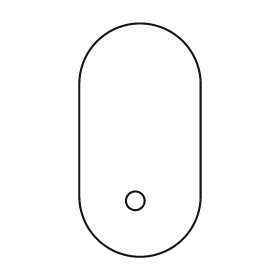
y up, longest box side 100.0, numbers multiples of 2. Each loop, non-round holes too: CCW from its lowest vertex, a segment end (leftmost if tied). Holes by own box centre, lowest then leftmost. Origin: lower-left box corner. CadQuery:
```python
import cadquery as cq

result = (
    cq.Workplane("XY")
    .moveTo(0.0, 26.0)
    .threePointArc((26.0, 0.0), (52.0, 26.0))
    .lineTo(52.0, 74.0)
    .threePointArc((26.0, 100.0), (0.0, 74.0))
    .close()
    .moveTo(24.0, 24.0)
    .circle(4.0)
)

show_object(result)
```